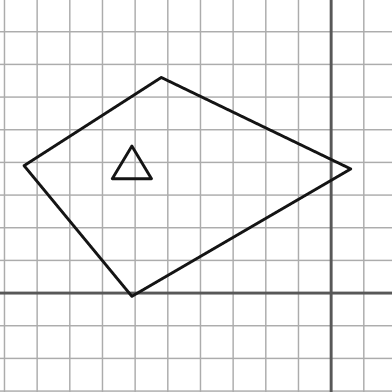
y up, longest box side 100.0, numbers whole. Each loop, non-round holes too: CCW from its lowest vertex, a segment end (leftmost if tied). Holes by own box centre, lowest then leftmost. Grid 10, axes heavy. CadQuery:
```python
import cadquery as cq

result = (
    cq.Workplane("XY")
    .moveTo(-61.0, -1.0)
    .lineTo(6.0, 38.0)
    .lineTo(-52.0, 66.0)
    .lineTo(-94.0, 39.0)
    .close()
    .moveTo(-67.0, 35.0)
    .lineTo(-55.0, 35.0)
    .lineTo(-61.0, 45.0)
    .close()
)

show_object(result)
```